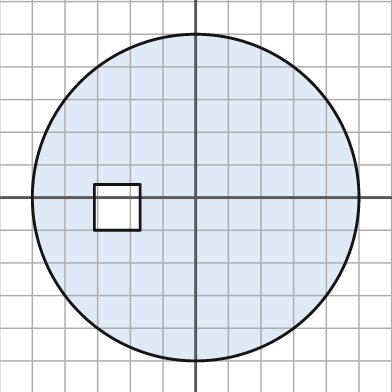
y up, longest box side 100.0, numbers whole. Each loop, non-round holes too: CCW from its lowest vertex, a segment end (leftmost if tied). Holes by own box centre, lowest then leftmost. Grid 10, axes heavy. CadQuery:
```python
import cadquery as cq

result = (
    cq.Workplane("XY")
    .moveTo(0.0, 0.0)
    .circle(50.0)
    .moveTo(-31.0, -10.0)
    .lineTo(-17.0, -10.0)
    .lineTo(-17.0, 4.0)
    .lineTo(-31.0, 4.0)
    .close()
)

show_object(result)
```